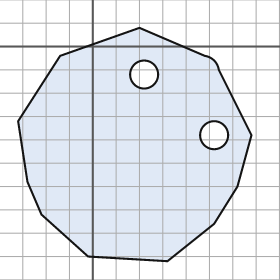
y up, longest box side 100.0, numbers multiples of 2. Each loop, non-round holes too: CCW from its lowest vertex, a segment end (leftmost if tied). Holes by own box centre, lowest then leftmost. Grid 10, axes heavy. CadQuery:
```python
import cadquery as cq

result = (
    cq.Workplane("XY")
    .moveTo(32.0, -92.0)
    .lineTo(52.0, -76.0)
    .lineTo(62.0, -60.0)
    .lineTo(68.0, -38.0)
    .lineTo(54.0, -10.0)
    .threePointArc((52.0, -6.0), (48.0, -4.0))
    .lineTo(20.0, 8.0)
    .lineTo(-14.0, -4.0)
    .lineTo(-32.0, -32.0)
    .lineTo(-28.0, -58.0)
    .lineTo(-22.0, -72.0)
    .lineTo(-2.0, -90.0)
    .close()
    .moveTo(52.0, -38.0)
    .circle(6.0)
    .moveTo(22.0, -12.0)
    .circle(6.0)
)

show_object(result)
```